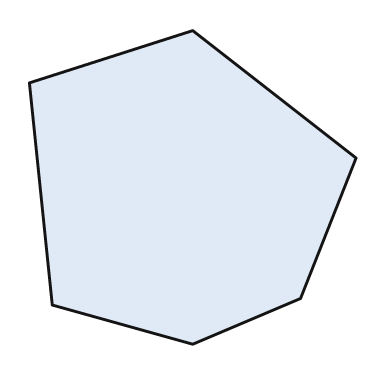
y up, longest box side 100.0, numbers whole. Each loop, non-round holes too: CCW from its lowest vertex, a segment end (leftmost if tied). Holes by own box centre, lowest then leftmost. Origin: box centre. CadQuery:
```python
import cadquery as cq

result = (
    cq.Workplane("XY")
    .moveTo(0.0, -48.0)
    .lineTo(33.0, -34.0)
    .lineTo(50.0, 9.0)
    .lineTo(0.0, 48.0)
    .lineTo(-50.0, 32.0)
    .lineTo(-43.0, -36.0)
    .close()
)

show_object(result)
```